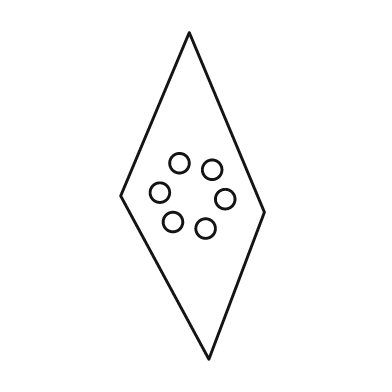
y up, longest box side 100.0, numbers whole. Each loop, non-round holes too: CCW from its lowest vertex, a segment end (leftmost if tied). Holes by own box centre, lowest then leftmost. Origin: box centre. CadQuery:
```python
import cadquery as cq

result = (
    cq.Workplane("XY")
    .moveTo(5.0, -50.0)
    .lineTo(22.0, -5.0)
    .lineTo(-1.0, 50.0)
    .lineTo(-22.0, 0.0)
    .close()
    .moveTo(4.0, -10.0)
    .circle(3.0)
    .moveTo(-6.0, -8.0)
    .circle(3.0)
    .moveTo(10.0, -1.0)
    .circle(3.0)
    .moveTo(-10.0, 1.0)
    .circle(3.0)
    .moveTo(6.0, 8.0)
    .circle(3.0)
    .moveTo(-4.0, 10.0)
    .circle(3.0)
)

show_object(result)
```